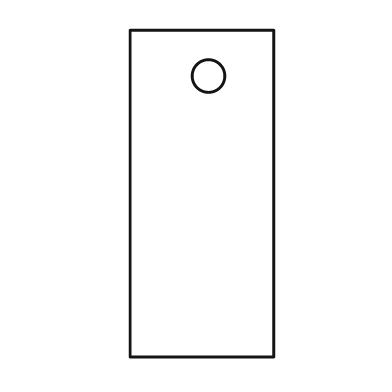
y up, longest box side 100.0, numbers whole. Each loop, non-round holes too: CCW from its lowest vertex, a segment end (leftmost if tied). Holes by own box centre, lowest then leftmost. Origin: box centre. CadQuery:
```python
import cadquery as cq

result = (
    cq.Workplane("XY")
    .moveTo(-22.0, -50.0)
    .lineTo(22.0, -50.0)
    .lineTo(22.0, 50.0)
    .lineTo(-22.0, 50.0)
    .close()
    .moveTo(2.0, 36.0)
    .circle(5.0)
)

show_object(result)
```